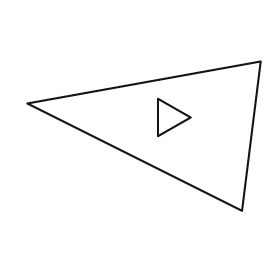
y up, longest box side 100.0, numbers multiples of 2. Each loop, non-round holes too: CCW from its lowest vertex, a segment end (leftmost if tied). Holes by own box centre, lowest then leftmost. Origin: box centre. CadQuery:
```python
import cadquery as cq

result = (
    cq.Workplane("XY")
    .moveTo(42.0, -32.0)
    .lineTo(50.0, 32.0)
    .lineTo(-50.0, 14.0)
    .close()
    .moveTo(6.0, 0.0)
    .lineTo(20.0, 8.0)
    .lineTo(6.0, 16.0)
    .close()
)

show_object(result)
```